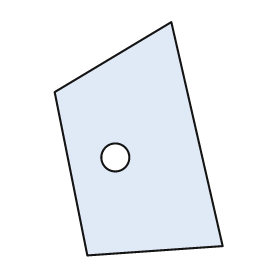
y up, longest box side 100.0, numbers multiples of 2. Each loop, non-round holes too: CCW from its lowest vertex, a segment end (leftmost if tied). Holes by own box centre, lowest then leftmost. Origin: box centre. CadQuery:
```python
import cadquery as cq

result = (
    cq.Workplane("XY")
    .moveTo(-22.0, -50.0)
    .lineTo(36.0, -46.0)
    .lineTo(14.0, 50.0)
    .lineTo(-36.0, 20.0)
    .close()
    .moveTo(-10.0, -8.0)
    .circle(6.0)
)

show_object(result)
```